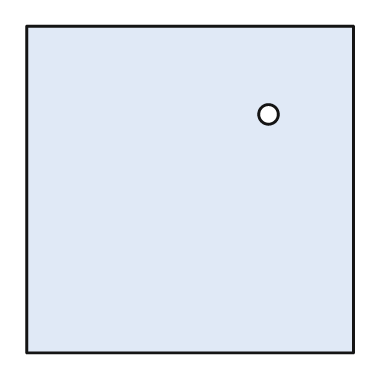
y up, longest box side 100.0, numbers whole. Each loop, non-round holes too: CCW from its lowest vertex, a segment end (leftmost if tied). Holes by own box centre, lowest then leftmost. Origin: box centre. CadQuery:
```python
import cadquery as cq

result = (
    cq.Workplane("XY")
    .moveTo(-50.0, -50.0)
    .lineTo(50.0, -50.0)
    .lineTo(50.0, 50.0)
    .lineTo(-50.0, 50.0)
    .close()
    .moveTo(24.0, 23.0)
    .circle(3.0)
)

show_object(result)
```